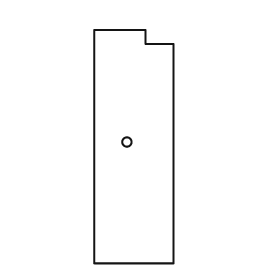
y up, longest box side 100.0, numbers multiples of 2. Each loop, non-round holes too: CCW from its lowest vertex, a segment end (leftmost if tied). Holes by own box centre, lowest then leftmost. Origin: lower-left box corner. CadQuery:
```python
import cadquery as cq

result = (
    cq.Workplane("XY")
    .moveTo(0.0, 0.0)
    .lineTo(34.0, 0.0)
    .lineTo(34.0, 94.0)
    .lineTo(22.0, 94.0)
    .lineTo(22.0, 100.0)
    .lineTo(0.0, 100.0)
    .close()
    .moveTo(14.0, 52.0)
    .circle(2.0)
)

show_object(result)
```